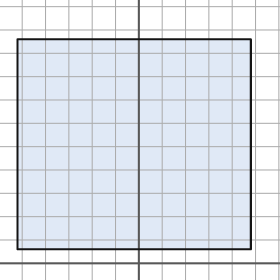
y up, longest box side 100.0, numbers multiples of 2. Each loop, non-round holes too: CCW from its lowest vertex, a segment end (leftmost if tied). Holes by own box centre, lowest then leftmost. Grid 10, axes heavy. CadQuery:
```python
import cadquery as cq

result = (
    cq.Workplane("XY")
    .moveTo(-52.0, 6.0)
    .lineTo(48.0, 6.0)
    .lineTo(48.0, 96.0)
    .lineTo(-52.0, 96.0)
    .close()
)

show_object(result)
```